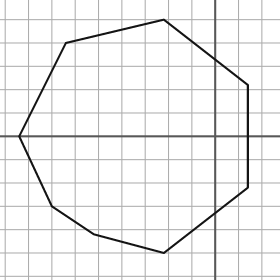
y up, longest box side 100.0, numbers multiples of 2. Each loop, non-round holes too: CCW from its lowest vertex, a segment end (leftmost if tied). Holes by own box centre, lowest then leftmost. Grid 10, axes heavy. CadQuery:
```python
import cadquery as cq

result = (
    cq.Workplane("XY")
    .moveTo(-22.0, -50.0)
    .lineTo(14.0, -22.0)
    .lineTo(14.0, 22.0)
    .lineTo(-22.0, 50.0)
    .lineTo(-64.0, 40.0)
    .lineTo(-84.0, 0.0)
    .lineTo(-70.0, -30.0)
    .lineTo(-52.0, -42.0)
    .close()
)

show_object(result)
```